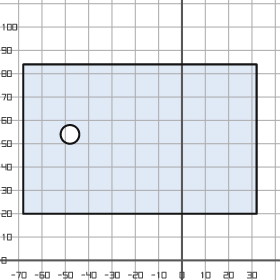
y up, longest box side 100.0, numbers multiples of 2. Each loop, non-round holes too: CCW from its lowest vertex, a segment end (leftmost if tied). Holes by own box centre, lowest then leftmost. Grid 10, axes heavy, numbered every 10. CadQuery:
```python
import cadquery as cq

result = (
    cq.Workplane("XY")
    .moveTo(-68.0, 20.0)
    .lineTo(32.0, 20.0)
    .lineTo(32.0, 84.0)
    .lineTo(-68.0, 84.0)
    .close()
    .moveTo(-48.0, 54.0)
    .circle(4.0)
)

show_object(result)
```